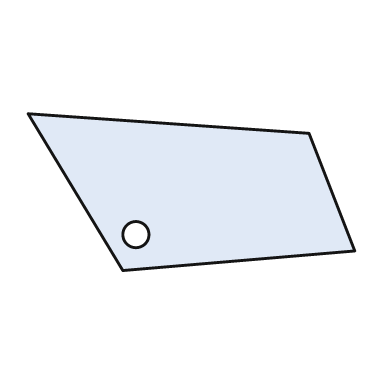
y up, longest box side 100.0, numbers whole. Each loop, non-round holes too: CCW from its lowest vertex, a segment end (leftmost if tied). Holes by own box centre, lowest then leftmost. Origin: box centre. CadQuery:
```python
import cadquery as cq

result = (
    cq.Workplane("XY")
    .moveTo(-21.0, -24.0)
    .lineTo(50.0, -18.0)
    .lineTo(36.0, 18.0)
    .lineTo(-50.0, 24.0)
    .close()
    .moveTo(-17.0, -13.0)
    .circle(4.0)
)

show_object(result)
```